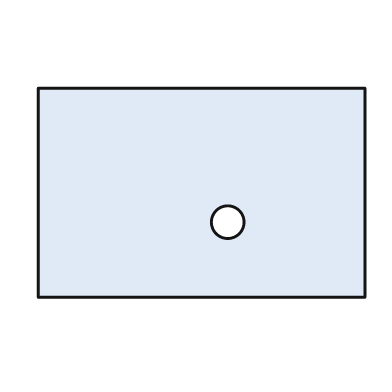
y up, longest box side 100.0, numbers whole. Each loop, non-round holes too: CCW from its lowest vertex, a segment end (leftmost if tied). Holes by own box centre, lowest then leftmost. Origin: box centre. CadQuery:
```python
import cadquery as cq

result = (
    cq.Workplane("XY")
    .moveTo(-50.0, -32.0)
    .lineTo(50.0, -32.0)
    .lineTo(50.0, 32.0)
    .lineTo(-50.0, 32.0)
    .close()
    .moveTo(8.0, -9.0)
    .circle(5.0)
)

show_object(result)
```